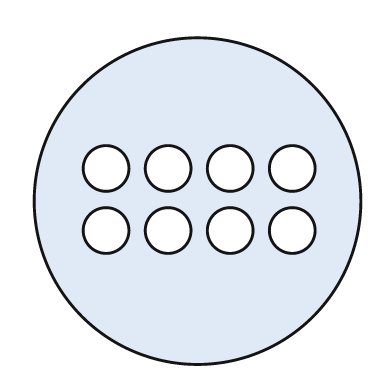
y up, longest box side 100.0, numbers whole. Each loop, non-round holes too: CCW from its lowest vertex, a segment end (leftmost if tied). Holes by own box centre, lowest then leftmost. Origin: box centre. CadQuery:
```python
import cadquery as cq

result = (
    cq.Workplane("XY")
    .moveTo(0.0, 0.0)
    .circle(50.0)
    .moveTo(-28.0, -9.0)
    .circle(7.0)
    .moveTo(-9.0, -9.0)
    .circle(7.0)
    .moveTo(10.0, -9.0)
    .circle(7.0)
    .moveTo(29.0, -9.0)
    .circle(7.0)
    .moveTo(-28.0, 10.0)
    .circle(7.0)
    .moveTo(-9.0, 10.0)
    .circle(7.0)
    .moveTo(10.0, 10.0)
    .circle(7.0)
    .moveTo(29.0, 10.0)
    .circle(7.0)
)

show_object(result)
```